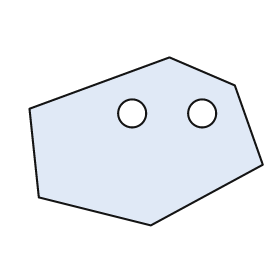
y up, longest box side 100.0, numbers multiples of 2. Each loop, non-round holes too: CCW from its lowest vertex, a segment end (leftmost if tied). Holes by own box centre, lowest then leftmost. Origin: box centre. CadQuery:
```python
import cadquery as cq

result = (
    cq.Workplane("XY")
    .moveTo(2.0, -36.0)
    .lineTo(50.0, -10.0)
    .lineTo(38.0, 24.0)
    .lineTo(10.0, 36.0)
    .lineTo(-50.0, 14.0)
    .lineTo(-46.0, -24.0)
    .close()
    .moveTo(-6.0, 12.0)
    .circle(6.0)
    .moveTo(24.0, 12.0)
    .circle(6.0)
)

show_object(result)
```